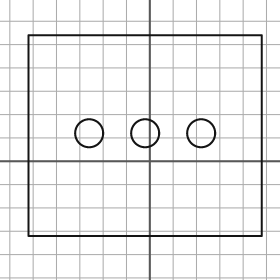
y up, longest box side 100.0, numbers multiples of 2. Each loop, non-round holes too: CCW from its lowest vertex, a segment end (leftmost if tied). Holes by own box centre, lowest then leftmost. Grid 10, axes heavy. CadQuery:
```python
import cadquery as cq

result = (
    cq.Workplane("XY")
    .moveTo(-52.0, -32.0)
    .lineTo(48.0, -32.0)
    .lineTo(48.0, 54.0)
    .lineTo(-52.0, 54.0)
    .close()
    .moveTo(-26.0, 12.0)
    .circle(6.0)
    .moveTo(-2.0, 12.0)
    .circle(6.0)
    .moveTo(22.0, 12.0)
    .circle(6.0)
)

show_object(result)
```